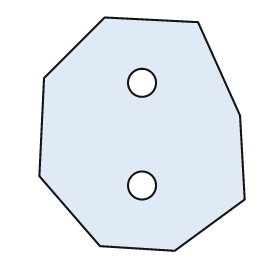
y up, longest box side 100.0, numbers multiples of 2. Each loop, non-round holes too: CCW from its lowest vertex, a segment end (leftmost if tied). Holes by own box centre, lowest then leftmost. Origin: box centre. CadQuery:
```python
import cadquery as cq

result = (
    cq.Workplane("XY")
    .moveTo(14.0, -50.0)
    .lineTo(44.0, -28.0)
    .lineTo(42.0, 8.0)
    .lineTo(24.0, 48.0)
    .lineTo(-16.0, 50.0)
    .lineTo(-42.0, 24.0)
    .lineTo(-44.0, -18.0)
    .lineTo(-18.0, -48.0)
    .close()
    .moveTo(0.0, -22.0)
    .circle(6.0)
    .moveTo(0.0, 22.0)
    .circle(6.0)
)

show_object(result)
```